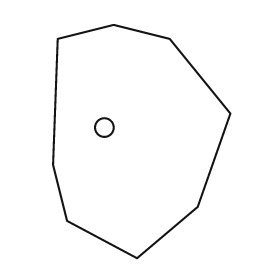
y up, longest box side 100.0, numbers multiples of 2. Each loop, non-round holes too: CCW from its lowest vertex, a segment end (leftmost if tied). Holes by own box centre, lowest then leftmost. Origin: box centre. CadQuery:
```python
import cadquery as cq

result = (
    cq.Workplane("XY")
    .moveTo(-2.0, -50.0)
    .lineTo(24.0, -28.0)
    .lineTo(38.0, 12.0)
    .lineTo(12.0, 44.0)
    .lineTo(-12.0, 50.0)
    .lineTo(-36.0, 44.0)
    .lineTo(-38.0, -10.0)
    .lineTo(-32.0, -34.0)
    .close()
    .moveTo(-16.0, 6.0)
    .circle(4.0)
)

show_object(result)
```